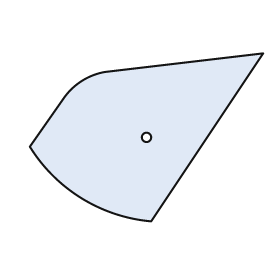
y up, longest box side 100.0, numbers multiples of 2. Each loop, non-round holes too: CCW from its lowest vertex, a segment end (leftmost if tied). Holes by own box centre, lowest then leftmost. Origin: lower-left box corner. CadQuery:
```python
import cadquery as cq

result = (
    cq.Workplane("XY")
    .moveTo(52.0, 0.0)
    .lineTo(100.0, 72.0)
    .lineTo(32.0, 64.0)
    .threePointArc((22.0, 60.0), (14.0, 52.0))
    .lineTo(0.0, 32.0)
    .threePointArc((22.0, 10.0), (52.0, 0.0))
    .close()
    .moveTo(50.0, 36.0)
    .circle(2.0)
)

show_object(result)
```